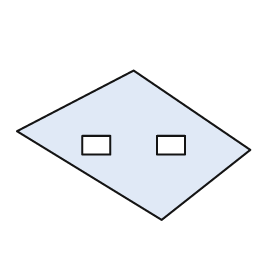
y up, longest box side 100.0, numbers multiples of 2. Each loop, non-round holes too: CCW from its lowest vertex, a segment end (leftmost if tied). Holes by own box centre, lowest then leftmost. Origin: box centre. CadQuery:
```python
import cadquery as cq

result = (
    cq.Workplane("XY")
    .moveTo(12.0, -32.0)
    .lineTo(50.0, -2.0)
    .lineTo(0.0, 32.0)
    .lineTo(-50.0, 6.0)
    .close()
    .moveTo(-22.0, -4.0)
    .lineTo(-10.0, -4.0)
    .lineTo(-10.0, 4.0)
    .lineTo(-22.0, 4.0)
    .close()
    .moveTo(10.0, -4.0)
    .lineTo(22.0, -4.0)
    .lineTo(22.0, 4.0)
    .lineTo(10.0, 4.0)
    .close()
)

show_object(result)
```